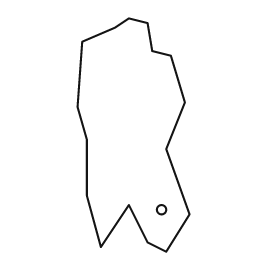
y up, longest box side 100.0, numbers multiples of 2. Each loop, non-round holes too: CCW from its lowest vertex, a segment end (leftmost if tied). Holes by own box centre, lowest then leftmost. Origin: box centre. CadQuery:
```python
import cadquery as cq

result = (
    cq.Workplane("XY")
    .moveTo(14.0, -50.0)
    .lineTo(24.0, -34.0)
    .lineTo(14.0, -6.0)
    .lineTo(22.0, 14.0)
    .lineTo(16.0, 34.0)
    .lineTo(8.0, 36.0)
    .lineTo(6.0, 48.0)
    .lineTo(-2.0, 50.0)
    .lineTo(-8.0, 46.0)
    .lineTo(-22.0, 40.0)
    .lineTo(-24.0, 12.0)
    .lineTo(-20.0, -2.0)
    .lineTo(-20.0, -26.0)
    .lineTo(-14.0, -48.0)
    .lineTo(-2.0, -30.0)
    .lineTo(6.0, -46.0)
    .close()
    .moveTo(12.0, -32.0)
    .circle(2.0)
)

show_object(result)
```